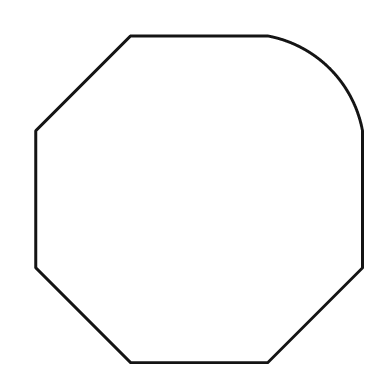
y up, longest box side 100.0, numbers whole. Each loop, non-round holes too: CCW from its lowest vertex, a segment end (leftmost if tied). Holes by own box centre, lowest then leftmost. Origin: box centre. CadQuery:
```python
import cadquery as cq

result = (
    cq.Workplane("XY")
    .moveTo(-21.0, -50.0)
    .lineTo(21.0, -50.0)
    .lineTo(50.0, -21.0)
    .lineTo(50.0, 21.0)
    .threePointArc((40.0, 40.0), (21.0, 50.0))
    .lineTo(-21.0, 50.0)
    .lineTo(-50.0, 21.0)
    .lineTo(-50.0, -21.0)
    .close()
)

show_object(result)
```